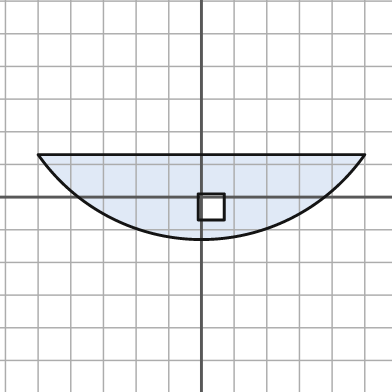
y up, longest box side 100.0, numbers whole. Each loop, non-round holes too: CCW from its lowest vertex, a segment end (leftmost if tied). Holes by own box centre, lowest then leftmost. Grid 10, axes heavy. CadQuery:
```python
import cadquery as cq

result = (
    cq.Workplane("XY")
    .moveTo(-50.0, 13.0)
    .threePointArc((0.0, -13.0), (50.0, 13.0))
    .close()
    .moveTo(-1.0, -7.0)
    .lineTo(7.0, -7.0)
    .lineTo(7.0, 1.0)
    .lineTo(-1.0, 1.0)
    .close()
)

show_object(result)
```